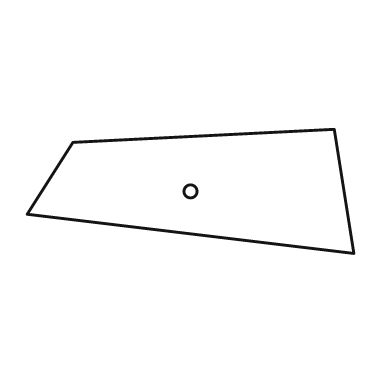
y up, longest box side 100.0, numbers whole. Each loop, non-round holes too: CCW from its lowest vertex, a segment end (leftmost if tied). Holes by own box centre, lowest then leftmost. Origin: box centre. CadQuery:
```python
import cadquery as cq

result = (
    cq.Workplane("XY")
    .moveTo(50.0, -19.0)
    .lineTo(44.0, 19.0)
    .lineTo(-36.0, 15.0)
    .lineTo(-50.0, -7.0)
    .close()
    .moveTo(0.0, 0.0)
    .circle(2.0)
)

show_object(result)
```